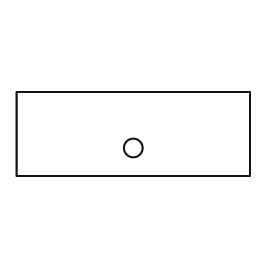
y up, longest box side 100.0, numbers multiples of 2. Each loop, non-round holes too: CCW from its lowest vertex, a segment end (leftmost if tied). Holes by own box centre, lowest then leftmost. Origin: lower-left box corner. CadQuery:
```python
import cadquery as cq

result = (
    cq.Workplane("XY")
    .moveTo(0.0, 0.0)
    .lineTo(100.0, 0.0)
    .lineTo(100.0, 36.0)
    .lineTo(0.0, 36.0)
    .close()
    .moveTo(50.0, 12.0)
    .circle(4.0)
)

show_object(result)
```